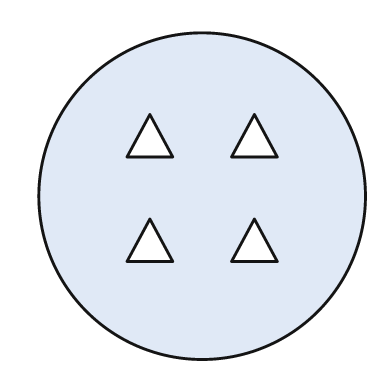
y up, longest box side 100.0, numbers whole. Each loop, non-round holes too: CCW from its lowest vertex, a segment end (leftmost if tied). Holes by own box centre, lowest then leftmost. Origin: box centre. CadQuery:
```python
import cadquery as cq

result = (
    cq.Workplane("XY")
    .moveTo(0.0, 0.0)
    .circle(50.0)
    .moveTo(-23.0, -20.0)
    .lineTo(-9.0, -20.0)
    .lineTo(-16.0, -7.0)
    .close()
    .moveTo(9.0, -20.0)
    .lineTo(23.0, -20.0)
    .lineTo(16.0, -7.0)
    .close()
    .moveTo(-23.0, 12.0)
    .lineTo(-9.0, 12.0)
    .lineTo(-16.0, 25.0)
    .close()
    .moveTo(9.0, 12.0)
    .lineTo(23.0, 12.0)
    .lineTo(16.0, 25.0)
    .close()
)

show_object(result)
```